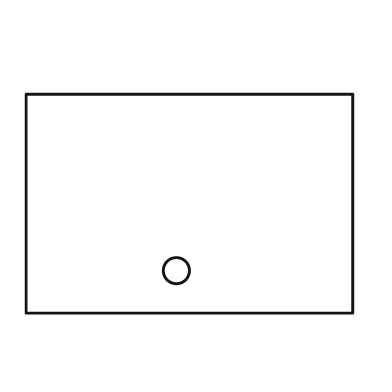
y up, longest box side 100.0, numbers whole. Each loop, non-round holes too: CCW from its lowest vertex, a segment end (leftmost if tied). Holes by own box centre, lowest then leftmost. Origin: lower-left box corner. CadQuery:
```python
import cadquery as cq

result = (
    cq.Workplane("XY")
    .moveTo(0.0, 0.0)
    .lineTo(100.0, 0.0)
    .lineTo(100.0, 67.0)
    .lineTo(0.0, 67.0)
    .close()
    .moveTo(46.0, 13.0)
    .circle(4.0)
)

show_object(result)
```